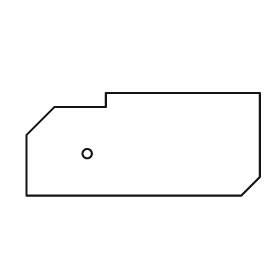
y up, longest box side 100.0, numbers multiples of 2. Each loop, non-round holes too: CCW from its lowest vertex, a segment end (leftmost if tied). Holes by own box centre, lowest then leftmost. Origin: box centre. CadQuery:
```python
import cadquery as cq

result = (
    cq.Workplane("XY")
    .moveTo(-50.0, -22.0)
    .lineTo(42.0, -22.0)
    .lineTo(50.0, -14.0)
    .lineTo(50.0, 22.0)
    .lineTo(-16.0, 22.0)
    .lineTo(-16.0, 16.0)
    .lineTo(-38.0, 16.0)
    .lineTo(-50.0, 4.0)
    .close()
    .moveTo(-24.0, -4.0)
    .circle(2.0)
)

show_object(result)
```